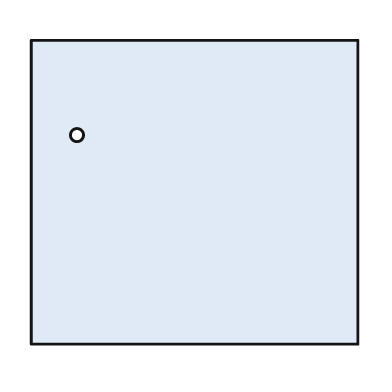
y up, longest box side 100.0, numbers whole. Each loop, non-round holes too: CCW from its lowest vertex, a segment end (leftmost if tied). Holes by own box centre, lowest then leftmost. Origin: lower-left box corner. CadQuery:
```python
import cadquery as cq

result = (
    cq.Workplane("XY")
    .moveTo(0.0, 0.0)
    .lineTo(100.0, 0.0)
    .lineTo(100.0, 93.0)
    .lineTo(0.0, 93.0)
    .close()
    .moveTo(14.0, 64.0)
    .circle(2.0)
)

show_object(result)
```